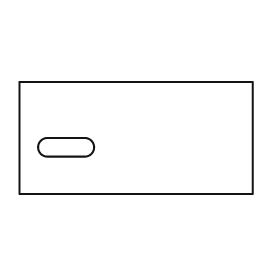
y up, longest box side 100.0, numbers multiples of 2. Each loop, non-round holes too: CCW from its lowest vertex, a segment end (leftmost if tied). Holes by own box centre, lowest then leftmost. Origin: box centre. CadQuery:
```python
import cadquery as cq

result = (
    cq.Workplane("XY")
    .moveTo(-50.0, -24.0)
    .lineTo(50.0, -24.0)
    .lineTo(50.0, 24.0)
    .lineTo(-50.0, 24.0)
    .close()
    .moveTo(-38.0, -8.0)
    .lineTo(-22.0, -8.0)
    .threePointArc((-18.0, -4.0), (-22.0, 0.0))
    .lineTo(-38.0, 0.0)
    .threePointArc((-42.0, -4.0), (-38.0, -8.0))
    .close()
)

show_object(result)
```